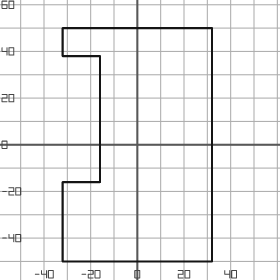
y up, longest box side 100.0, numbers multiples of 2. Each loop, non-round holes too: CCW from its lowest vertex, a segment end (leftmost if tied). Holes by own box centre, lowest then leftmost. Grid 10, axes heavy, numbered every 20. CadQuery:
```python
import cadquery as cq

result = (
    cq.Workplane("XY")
    .moveTo(-32.0, -50.0)
    .lineTo(32.0, -50.0)
    .lineTo(32.0, 50.0)
    .lineTo(-32.0, 50.0)
    .lineTo(-32.0, 38.0)
    .lineTo(-16.0, 38.0)
    .lineTo(-16.0, -16.0)
    .lineTo(-32.0, -16.0)
    .close()
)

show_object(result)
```